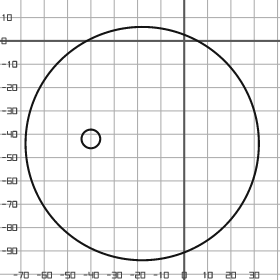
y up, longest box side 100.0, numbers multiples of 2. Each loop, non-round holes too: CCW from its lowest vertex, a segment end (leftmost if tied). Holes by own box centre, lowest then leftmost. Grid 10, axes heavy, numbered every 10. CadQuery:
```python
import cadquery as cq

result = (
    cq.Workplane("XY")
    .moveTo(-18.0, -44.0)
    .circle(50.0)
    .moveTo(-40.0, -42.0)
    .circle(4.0)
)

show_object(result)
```